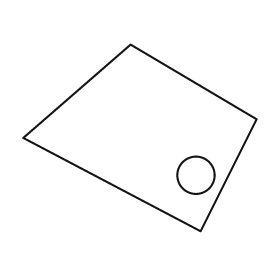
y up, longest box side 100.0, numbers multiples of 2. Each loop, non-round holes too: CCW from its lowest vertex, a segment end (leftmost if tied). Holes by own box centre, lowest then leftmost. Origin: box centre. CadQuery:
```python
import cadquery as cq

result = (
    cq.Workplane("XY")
    .moveTo(26.0, -40.0)
    .lineTo(50.0, 8.0)
    .lineTo(-4.0, 40.0)
    .lineTo(-50.0, 0.0)
    .close()
    .moveTo(24.0, -16.0)
    .circle(8.0)
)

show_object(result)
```